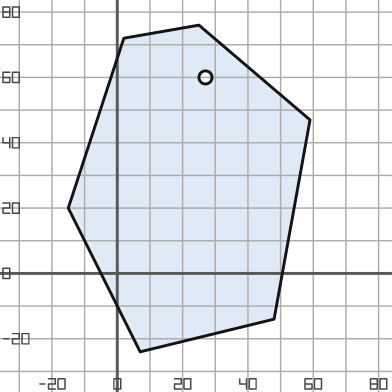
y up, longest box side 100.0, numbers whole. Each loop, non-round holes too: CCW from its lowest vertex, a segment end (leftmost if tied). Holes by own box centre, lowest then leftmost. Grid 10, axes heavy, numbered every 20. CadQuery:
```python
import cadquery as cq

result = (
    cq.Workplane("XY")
    .moveTo(7.0, -24.0)
    .lineTo(48.0, -14.0)
    .lineTo(59.0, 47.0)
    .lineTo(25.0, 76.0)
    .lineTo(2.0, 72.0)
    .lineTo(-15.0, 20.0)
    .close()
    .moveTo(27.0, 60.0)
    .circle(2.0)
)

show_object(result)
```